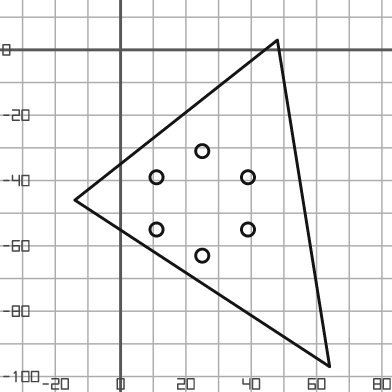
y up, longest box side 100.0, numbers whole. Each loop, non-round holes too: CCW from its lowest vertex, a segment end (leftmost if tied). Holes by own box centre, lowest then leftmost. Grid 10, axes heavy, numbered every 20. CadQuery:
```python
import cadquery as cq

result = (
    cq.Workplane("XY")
    .moveTo(64.0, -97.0)
    .lineTo(48.0, 3.0)
    .lineTo(-14.0, -46.0)
    .close()
    .moveTo(25.0, -63.0)
    .circle(2.0)
    .moveTo(11.0, -55.0)
    .circle(2.0)
    .moveTo(39.0, -55.0)
    .circle(2.0)
    .moveTo(11.0, -39.0)
    .circle(2.0)
    .moveTo(39.0, -39.0)
    .circle(2.0)
    .moveTo(25.0, -31.0)
    .circle(2.0)
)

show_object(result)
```